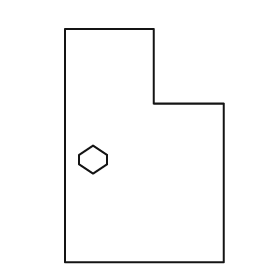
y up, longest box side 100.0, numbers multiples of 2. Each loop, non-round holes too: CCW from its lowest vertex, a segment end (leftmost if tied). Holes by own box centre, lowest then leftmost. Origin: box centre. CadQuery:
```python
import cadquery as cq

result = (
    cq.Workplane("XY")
    .moveTo(-34.0, -50.0)
    .lineTo(34.0, -50.0)
    .lineTo(34.0, 18.0)
    .lineTo(4.0, 18.0)
    .lineTo(4.0, 50.0)
    .lineTo(-34.0, 50.0)
    .close()
    .moveTo(-22.0, -12.0)
    .lineTo(-16.0, -8.0)
    .lineTo(-16.0, -4.0)
    .lineTo(-22.0, 0.0)
    .lineTo(-28.0, -4.0)
    .lineTo(-28.0, -8.0)
    .close()
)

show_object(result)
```